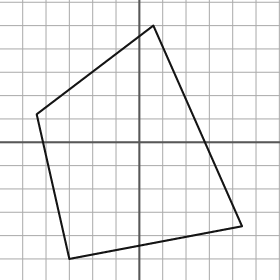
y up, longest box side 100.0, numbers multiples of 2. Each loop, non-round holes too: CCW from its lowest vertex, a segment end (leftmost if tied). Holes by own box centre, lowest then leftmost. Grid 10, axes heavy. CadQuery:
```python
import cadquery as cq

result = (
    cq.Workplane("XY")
    .moveTo(-30.0, -50.0)
    .lineTo(44.0, -36.0)
    .lineTo(6.0, 50.0)
    .lineTo(-44.0, 12.0)
    .close()
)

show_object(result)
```